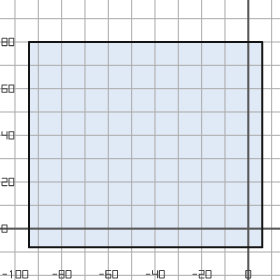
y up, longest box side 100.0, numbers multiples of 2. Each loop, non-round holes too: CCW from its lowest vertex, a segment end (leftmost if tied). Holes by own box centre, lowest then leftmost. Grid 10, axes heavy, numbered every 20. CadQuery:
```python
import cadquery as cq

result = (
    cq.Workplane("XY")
    .moveTo(-94.0, -8.0)
    .lineTo(6.0, -8.0)
    .lineTo(6.0, 80.0)
    .lineTo(-94.0, 80.0)
    .close()
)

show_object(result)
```